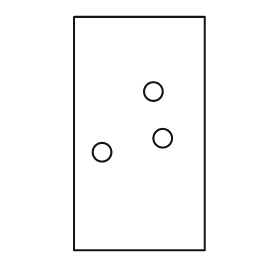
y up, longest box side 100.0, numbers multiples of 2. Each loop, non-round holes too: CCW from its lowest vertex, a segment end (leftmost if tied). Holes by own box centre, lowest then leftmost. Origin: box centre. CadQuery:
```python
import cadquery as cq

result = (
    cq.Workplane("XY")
    .moveTo(-28.0, -50.0)
    .lineTo(28.0, -50.0)
    .lineTo(28.0, 50.0)
    .lineTo(-28.0, 50.0)
    .close()
    .moveTo(-16.0, -8.0)
    .circle(4.0)
    .moveTo(10.0, -2.0)
    .circle(4.0)
    .moveTo(6.0, 18.0)
    .circle(4.0)
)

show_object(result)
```